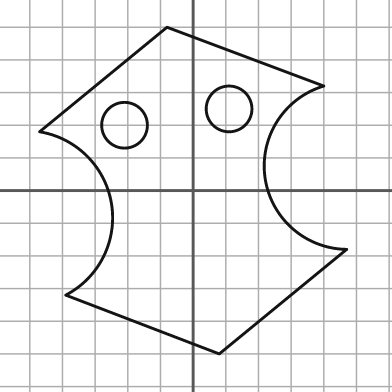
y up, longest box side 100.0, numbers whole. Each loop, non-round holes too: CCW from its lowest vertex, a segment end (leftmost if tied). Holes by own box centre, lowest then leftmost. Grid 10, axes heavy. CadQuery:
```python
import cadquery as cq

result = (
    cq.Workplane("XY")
    .moveTo(8.0, -50.0)
    .lineTo(47.0, -18.0)
    .threePointArc((22.0, 4.0), (40.0, 32.0))
    .lineTo(-8.0, 50.0)
    .lineTo(-47.0, 18.0)
    .threePointArc((-25.0, -4.0), (-39.0, -32.0))
    .close()
    .moveTo(-21.0, 20.0)
    .circle(7.0)
    .moveTo(11.0, 25.0)
    .circle(7.0)
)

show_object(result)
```